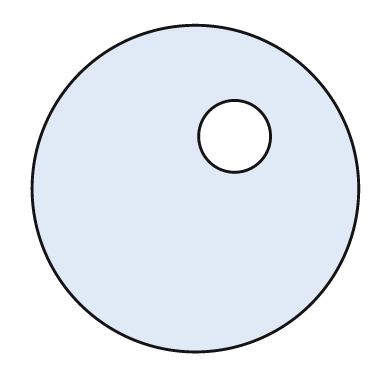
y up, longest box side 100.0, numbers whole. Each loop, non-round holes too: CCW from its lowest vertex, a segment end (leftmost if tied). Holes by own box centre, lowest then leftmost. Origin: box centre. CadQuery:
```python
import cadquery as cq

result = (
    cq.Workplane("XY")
    .moveTo(0.0, 0.0)
    .circle(50.0)
    .moveTo(12.0, 16.0)
    .circle(11.0)
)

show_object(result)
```